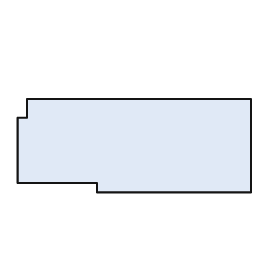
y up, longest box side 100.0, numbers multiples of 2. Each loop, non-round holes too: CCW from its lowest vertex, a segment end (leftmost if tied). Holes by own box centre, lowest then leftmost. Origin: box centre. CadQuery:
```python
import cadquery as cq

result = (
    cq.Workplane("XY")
    .moveTo(-16.0, -20.0)
    .lineTo(50.0, -20.0)
    .lineTo(50.0, 20.0)
    .lineTo(-46.0, 20.0)
    .lineTo(-46.0, 12.0)
    .lineTo(-50.0, 12.0)
    .lineTo(-50.0, -16.0)
    .lineTo(-16.0, -16.0)
    .close()
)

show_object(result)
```